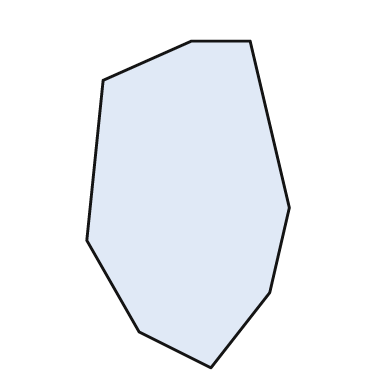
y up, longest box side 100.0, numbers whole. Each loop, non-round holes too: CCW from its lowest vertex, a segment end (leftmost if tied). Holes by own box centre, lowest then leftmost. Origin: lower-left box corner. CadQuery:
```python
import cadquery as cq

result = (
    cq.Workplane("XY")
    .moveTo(38.0, 0.0)
    .lineTo(56.0, 23.0)
    .lineTo(62.0, 49.0)
    .lineTo(50.0, 100.0)
    .lineTo(32.0, 100.0)
    .lineTo(5.0, 88.0)
    .lineTo(0.0, 39.0)
    .lineTo(16.0, 11.0)
    .close()
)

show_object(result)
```